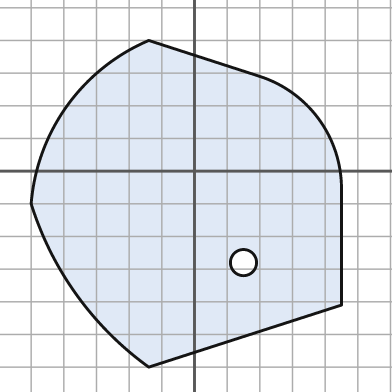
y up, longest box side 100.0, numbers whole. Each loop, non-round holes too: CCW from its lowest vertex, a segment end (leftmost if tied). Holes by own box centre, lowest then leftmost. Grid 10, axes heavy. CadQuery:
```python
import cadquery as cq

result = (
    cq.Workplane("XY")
    .moveTo(-14.0, -60.0)
    .lineTo(45.0, -41.0)
    .lineTo(45.0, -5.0)
    .threePointArc((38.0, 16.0), (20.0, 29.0))
    .lineTo(-14.0, 40.0)
    .threePointArc((-39.0, 20.0), (-50.0, -10.0))
    .threePointArc((-36.0, -38.0), (-14.0, -60.0))
    .close()
    .moveTo(15.0, -28.0)
    .circle(4.0)
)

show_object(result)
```